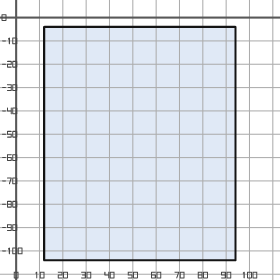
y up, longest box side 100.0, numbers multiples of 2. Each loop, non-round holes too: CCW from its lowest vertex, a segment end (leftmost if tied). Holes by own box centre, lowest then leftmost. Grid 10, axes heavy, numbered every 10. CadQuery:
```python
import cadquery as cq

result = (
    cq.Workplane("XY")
    .moveTo(12.0, -104.0)
    .lineTo(94.0, -104.0)
    .lineTo(94.0, -4.0)
    .lineTo(12.0, -4.0)
    .close()
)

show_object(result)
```